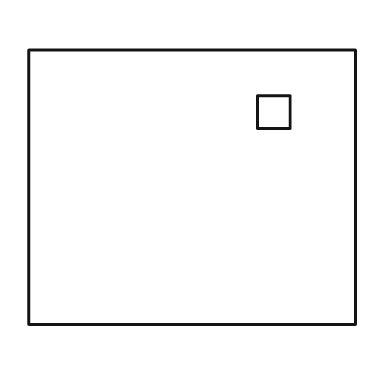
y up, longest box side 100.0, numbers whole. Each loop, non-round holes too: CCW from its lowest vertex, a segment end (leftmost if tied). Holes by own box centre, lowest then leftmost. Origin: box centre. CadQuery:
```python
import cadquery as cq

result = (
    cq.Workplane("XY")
    .moveTo(-50.0, -42.0)
    .lineTo(50.0, -42.0)
    .lineTo(50.0, 42.0)
    .lineTo(-50.0, 42.0)
    .close()
    .moveTo(20.0, 18.0)
    .lineTo(30.0, 18.0)
    .lineTo(30.0, 28.0)
    .lineTo(20.0, 28.0)
    .close()
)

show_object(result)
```